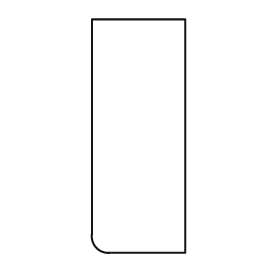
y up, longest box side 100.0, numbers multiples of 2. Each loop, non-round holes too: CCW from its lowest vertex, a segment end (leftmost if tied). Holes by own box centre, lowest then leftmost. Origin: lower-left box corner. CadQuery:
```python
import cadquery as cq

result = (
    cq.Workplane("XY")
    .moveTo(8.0, 0.0)
    .lineTo(40.0, 0.0)
    .lineTo(40.0, 100.0)
    .lineTo(0.0, 100.0)
    .lineTo(0.0, 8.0)
    .threePointArc((2.0, 2.0), (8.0, 0.0))
    .close()
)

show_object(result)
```